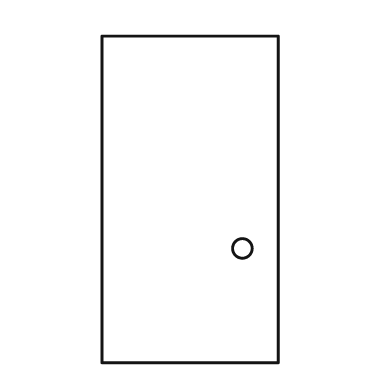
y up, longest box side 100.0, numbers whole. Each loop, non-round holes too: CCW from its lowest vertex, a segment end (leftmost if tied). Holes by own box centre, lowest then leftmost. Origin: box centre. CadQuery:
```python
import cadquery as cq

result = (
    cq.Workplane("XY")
    .moveTo(-27.0, -50.0)
    .lineTo(27.0, -50.0)
    .lineTo(27.0, 50.0)
    .lineTo(-27.0, 50.0)
    .close()
    .moveTo(16.0, -15.0)
    .circle(3.0)
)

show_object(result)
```